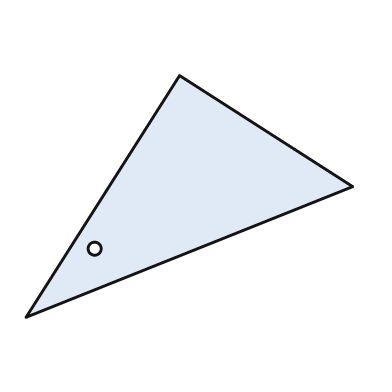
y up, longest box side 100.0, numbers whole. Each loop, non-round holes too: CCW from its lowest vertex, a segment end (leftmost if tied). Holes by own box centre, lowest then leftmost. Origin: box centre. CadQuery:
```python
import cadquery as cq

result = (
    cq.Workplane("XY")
    .moveTo(-50.0, -37.0)
    .lineTo(50.0, 3.0)
    .lineTo(-3.0, 37.0)
    .close()
    .moveTo(-29.0, -16.0)
    .circle(2.0)
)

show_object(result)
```